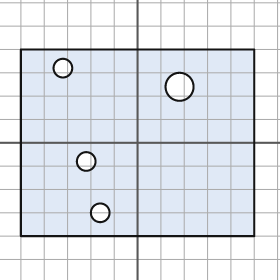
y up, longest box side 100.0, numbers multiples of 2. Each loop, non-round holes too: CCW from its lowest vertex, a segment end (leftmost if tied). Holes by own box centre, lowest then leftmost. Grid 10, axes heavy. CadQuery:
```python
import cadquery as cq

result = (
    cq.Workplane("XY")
    .moveTo(-50.0, -40.0)
    .lineTo(50.0, -40.0)
    .lineTo(50.0, 40.0)
    .lineTo(-50.0, 40.0)
    .close()
    .moveTo(-16.0, -30.0)
    .circle(4.0)
    .moveTo(-22.0, -8.0)
    .circle(4.0)
    .moveTo(18.0, 24.0)
    .circle(6.0)
    .moveTo(-32.0, 32.0)
    .circle(4.0)
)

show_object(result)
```